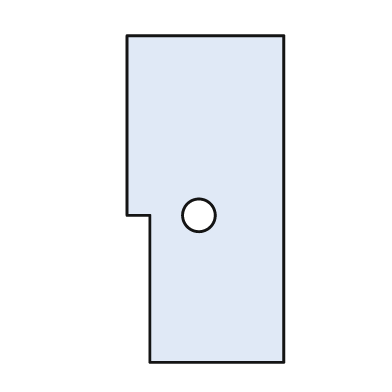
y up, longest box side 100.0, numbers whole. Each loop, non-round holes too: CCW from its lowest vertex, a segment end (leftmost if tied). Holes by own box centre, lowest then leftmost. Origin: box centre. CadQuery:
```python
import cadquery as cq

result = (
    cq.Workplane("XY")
    .moveTo(-17.0, -50.0)
    .lineTo(24.0, -50.0)
    .lineTo(24.0, 50.0)
    .lineTo(-24.0, 50.0)
    .lineTo(-24.0, -5.0)
    .lineTo(-17.0, -5.0)
    .close()
    .moveTo(-2.0, -5.0)
    .circle(5.0)
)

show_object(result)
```